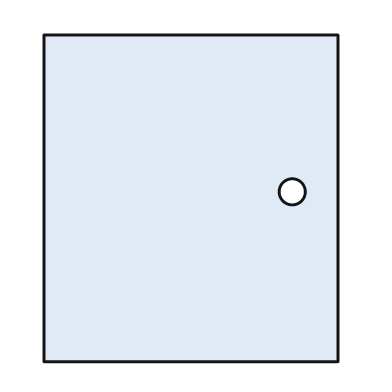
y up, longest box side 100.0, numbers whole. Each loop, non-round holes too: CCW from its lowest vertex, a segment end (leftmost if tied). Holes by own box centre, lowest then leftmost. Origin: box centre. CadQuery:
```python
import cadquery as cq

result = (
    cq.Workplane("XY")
    .moveTo(-45.0, -50.0)
    .lineTo(45.0, -50.0)
    .lineTo(45.0, 50.0)
    .lineTo(-45.0, 50.0)
    .close()
    .moveTo(31.0, 2.0)
    .circle(4.0)
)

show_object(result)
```